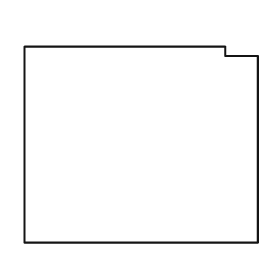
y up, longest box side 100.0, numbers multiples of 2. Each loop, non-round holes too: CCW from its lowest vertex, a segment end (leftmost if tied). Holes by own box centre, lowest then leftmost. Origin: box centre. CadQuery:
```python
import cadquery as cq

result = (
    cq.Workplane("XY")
    .moveTo(-50.0, -42.0)
    .lineTo(50.0, -42.0)
    .lineTo(50.0, 38.0)
    .lineTo(36.0, 38.0)
    .lineTo(36.0, 42.0)
    .lineTo(-50.0, 42.0)
    .close()
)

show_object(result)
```